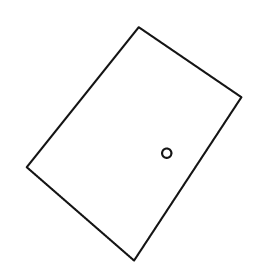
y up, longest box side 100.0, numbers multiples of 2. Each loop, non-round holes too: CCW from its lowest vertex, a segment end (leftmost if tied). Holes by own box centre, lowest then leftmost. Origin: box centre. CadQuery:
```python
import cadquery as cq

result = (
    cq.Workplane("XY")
    .moveTo(0.0, -50.0)
    .lineTo(46.0, 20.0)
    .lineTo(2.0, 50.0)
    .lineTo(-46.0, -10.0)
    .close()
    .moveTo(14.0, -4.0)
    .circle(2.0)
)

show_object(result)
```